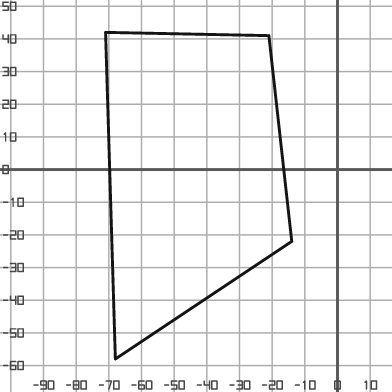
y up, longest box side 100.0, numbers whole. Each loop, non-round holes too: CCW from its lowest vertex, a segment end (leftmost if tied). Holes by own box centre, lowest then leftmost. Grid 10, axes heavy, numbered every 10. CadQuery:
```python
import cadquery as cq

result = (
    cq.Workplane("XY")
    .moveTo(-68.0, -58.0)
    .lineTo(-14.0, -22.0)
    .lineTo(-21.0, 41.0)
    .lineTo(-71.0, 42.0)
    .close()
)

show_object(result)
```